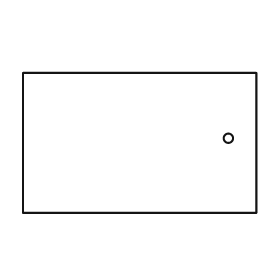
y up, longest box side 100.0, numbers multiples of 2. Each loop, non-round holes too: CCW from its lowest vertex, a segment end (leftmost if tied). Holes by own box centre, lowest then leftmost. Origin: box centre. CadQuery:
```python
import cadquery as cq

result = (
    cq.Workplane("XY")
    .moveTo(-50.0, -30.0)
    .lineTo(50.0, -30.0)
    .lineTo(50.0, 30.0)
    .lineTo(-50.0, 30.0)
    .close()
    .moveTo(38.0, 2.0)
    .circle(2.0)
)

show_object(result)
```